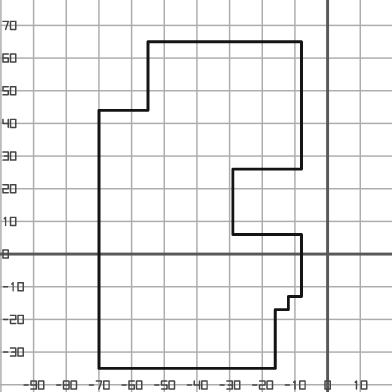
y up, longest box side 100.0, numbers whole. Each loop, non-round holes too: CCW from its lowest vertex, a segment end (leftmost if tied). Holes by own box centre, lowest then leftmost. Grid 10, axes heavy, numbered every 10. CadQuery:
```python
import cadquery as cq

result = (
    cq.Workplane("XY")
    .moveTo(-70.0, -35.0)
    .lineTo(-16.0, -35.0)
    .lineTo(-16.0, -17.0)
    .lineTo(-12.0, -17.0)
    .lineTo(-12.0, -13.0)
    .lineTo(-8.0, -13.0)
    .lineTo(-8.0, 6.0)
    .lineTo(-29.0, 6.0)
    .lineTo(-29.0, 26.0)
    .lineTo(-8.0, 26.0)
    .lineTo(-8.0, 65.0)
    .lineTo(-55.0, 65.0)
    .lineTo(-55.0, 44.0)
    .lineTo(-70.0, 44.0)
    .close()
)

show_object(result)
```